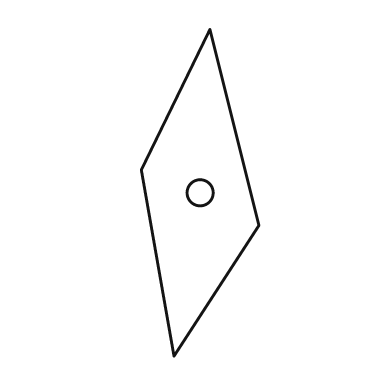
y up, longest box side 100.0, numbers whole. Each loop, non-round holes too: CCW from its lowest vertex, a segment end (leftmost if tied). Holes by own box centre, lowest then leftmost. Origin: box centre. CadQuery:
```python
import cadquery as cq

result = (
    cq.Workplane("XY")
    .moveTo(-8.0, -50.0)
    .lineTo(18.0, -10.0)
    .lineTo(3.0, 50.0)
    .lineTo(-18.0, 7.0)
    .close()
    .moveTo(0.0, 0.0)
    .circle(4.0)
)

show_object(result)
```